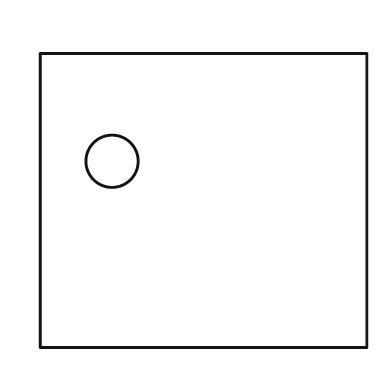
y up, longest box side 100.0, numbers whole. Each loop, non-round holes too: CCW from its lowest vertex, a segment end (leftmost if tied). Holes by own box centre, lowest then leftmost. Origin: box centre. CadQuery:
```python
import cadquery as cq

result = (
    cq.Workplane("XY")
    .moveTo(-50.0, -45.0)
    .lineTo(50.0, -45.0)
    .lineTo(50.0, 45.0)
    .lineTo(-50.0, 45.0)
    .close()
    .moveTo(-28.0, 12.0)
    .circle(8.0)
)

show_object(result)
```